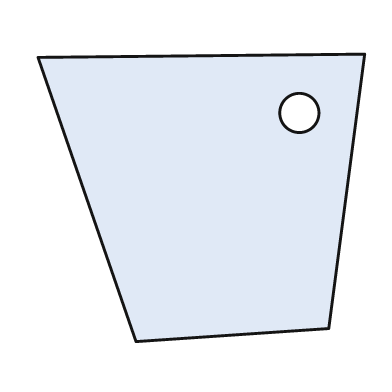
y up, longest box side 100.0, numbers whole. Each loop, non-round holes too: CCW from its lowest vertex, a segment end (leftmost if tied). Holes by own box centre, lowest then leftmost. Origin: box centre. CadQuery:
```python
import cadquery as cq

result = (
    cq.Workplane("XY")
    .moveTo(-20.0, -44.0)
    .lineTo(39.0, -40.0)
    .lineTo(50.0, 44.0)
    .lineTo(-50.0, 43.0)
    .close()
    .moveTo(30.0, 26.0)
    .circle(6.0)
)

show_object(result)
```